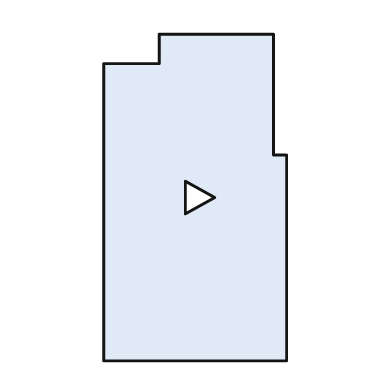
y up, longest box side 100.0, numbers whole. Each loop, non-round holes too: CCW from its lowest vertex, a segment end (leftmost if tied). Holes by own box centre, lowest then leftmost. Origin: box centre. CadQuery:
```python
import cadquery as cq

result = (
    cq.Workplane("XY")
    .moveTo(-28.0, -50.0)
    .lineTo(28.0, -50.0)
    .lineTo(28.0, 13.0)
    .lineTo(24.0, 13.0)
    .lineTo(24.0, 50.0)
    .lineTo(-11.0, 50.0)
    .lineTo(-11.0, 41.0)
    .lineTo(-28.0, 41.0)
    .close()
    .moveTo(-3.0, -5.0)
    .lineTo(6.0, 0.0)
    .lineTo(-3.0, 5.0)
    .close()
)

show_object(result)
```